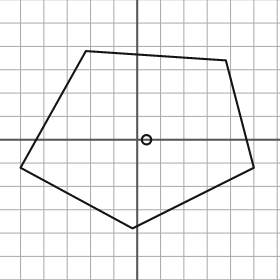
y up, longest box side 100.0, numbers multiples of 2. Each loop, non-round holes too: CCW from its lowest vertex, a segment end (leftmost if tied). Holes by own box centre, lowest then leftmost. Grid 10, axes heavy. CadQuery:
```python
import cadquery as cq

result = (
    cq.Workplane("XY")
    .moveTo(-2.0, -38.0)
    .lineTo(50.0, -12.0)
    .lineTo(38.0, 34.0)
    .lineTo(-22.0, 38.0)
    .lineTo(-50.0, -12.0)
    .close()
    .moveTo(4.0, 0.0)
    .circle(2.0)
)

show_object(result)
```